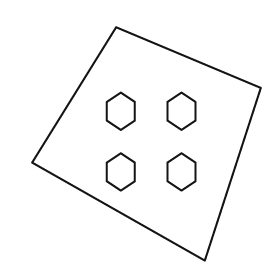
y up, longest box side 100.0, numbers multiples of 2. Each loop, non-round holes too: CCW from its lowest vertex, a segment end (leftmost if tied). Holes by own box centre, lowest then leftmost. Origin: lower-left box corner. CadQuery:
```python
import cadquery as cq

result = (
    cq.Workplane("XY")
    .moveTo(74.0, 0.0)
    .lineTo(98.0, 74.0)
    .lineTo(36.0, 100.0)
    .lineTo(0.0, 42.0)
    .close()
    .moveTo(38.0, 30.0)
    .lineTo(44.0, 34.0)
    .lineTo(44.0, 42.0)
    .lineTo(38.0, 46.0)
    .lineTo(32.0, 42.0)
    .lineTo(32.0, 34.0)
    .close()
    .moveTo(64.0, 30.0)
    .lineTo(70.0, 34.0)
    .lineTo(70.0, 42.0)
    .lineTo(64.0, 46.0)
    .lineTo(58.0, 42.0)
    .lineTo(58.0, 34.0)
    .close()
    .moveTo(38.0, 56.0)
    .lineTo(44.0, 60.0)
    .lineTo(44.0, 68.0)
    .lineTo(38.0, 72.0)
    .lineTo(32.0, 68.0)
    .lineTo(32.0, 60.0)
    .close()
    .moveTo(64.0, 56.0)
    .lineTo(70.0, 60.0)
    .lineTo(70.0, 68.0)
    .lineTo(64.0, 72.0)
    .lineTo(58.0, 68.0)
    .lineTo(58.0, 60.0)
    .close()
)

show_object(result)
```